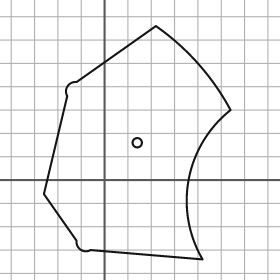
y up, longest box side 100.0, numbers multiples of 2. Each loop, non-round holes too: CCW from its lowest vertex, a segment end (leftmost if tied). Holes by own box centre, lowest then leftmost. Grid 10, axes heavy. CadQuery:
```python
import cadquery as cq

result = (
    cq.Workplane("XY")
    .moveTo(42.0, -34.0)
    .threePointArc((36.0, 0.0), (54.0, 30.0))
    .threePointArc((40.0, 50.0), (22.0, 66.0))
    .lineTo(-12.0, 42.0)
    .threePointArc((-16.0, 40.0), (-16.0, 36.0))
    .lineTo(-26.0, -6.0)
    .lineTo(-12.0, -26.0)
    .threePointArc((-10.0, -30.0), (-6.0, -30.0))
    .close()
    .moveTo(14.0, 16.0)
    .circle(2.0)
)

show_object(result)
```